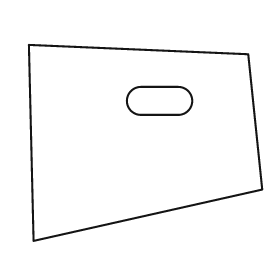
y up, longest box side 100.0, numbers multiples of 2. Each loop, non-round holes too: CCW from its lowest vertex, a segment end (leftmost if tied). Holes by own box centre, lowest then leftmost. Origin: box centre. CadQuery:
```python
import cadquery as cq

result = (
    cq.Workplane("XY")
    .moveTo(-48.0, -42.0)
    .lineTo(50.0, -20.0)
    .lineTo(44.0, 38.0)
    .lineTo(-50.0, 42.0)
    .close()
    .moveTo(-2.0, 12.0)
    .lineTo(14.0, 12.0)
    .threePointArc((20.0, 18.0), (14.0, 24.0))
    .lineTo(-2.0, 24.0)
    .threePointArc((-8.0, 18.0), (-2.0, 12.0))
    .close()
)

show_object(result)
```